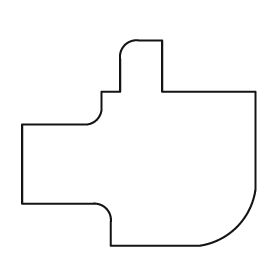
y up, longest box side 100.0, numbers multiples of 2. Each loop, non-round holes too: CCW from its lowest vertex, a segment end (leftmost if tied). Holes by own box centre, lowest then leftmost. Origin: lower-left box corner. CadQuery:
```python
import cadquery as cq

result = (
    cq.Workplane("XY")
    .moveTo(38.0, 0.0)
    .lineTo(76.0, 0.0)
    .threePointArc((92.0, 8.0), (100.0, 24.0))
    .lineTo(100.0, 66.0)
    .lineTo(60.0, 66.0)
    .lineTo(60.0, 88.0)
    .lineTo(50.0, 88.0)
    .threePointArc((44.0, 86.0), (42.0, 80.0))
    .lineTo(42.0, 66.0)
    .lineTo(34.0, 66.0)
    .lineTo(34.0, 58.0)
    .threePointArc((32.0, 54.0), (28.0, 52.0))
    .lineTo(0.0, 52.0)
    .lineTo(0.0, 18.0)
    .lineTo(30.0, 18.0)
    .threePointArc((36.0, 16.0), (38.0, 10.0))
    .close()
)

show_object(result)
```